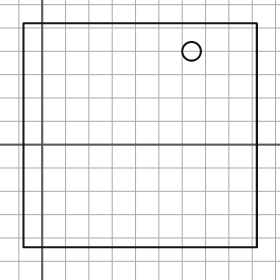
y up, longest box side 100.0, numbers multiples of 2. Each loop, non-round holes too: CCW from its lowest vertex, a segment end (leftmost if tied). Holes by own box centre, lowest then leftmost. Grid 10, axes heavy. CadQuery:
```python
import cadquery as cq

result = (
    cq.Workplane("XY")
    .moveTo(-8.0, -44.0)
    .lineTo(92.0, -44.0)
    .lineTo(92.0, 52.0)
    .lineTo(-8.0, 52.0)
    .close()
    .moveTo(64.0, 40.0)
    .circle(4.0)
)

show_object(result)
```